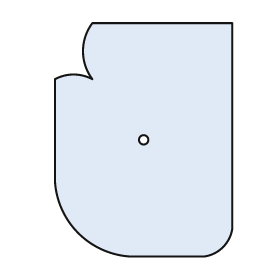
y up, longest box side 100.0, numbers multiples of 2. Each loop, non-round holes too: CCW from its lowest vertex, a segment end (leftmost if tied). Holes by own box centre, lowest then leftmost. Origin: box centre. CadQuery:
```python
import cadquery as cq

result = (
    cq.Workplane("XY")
    .moveTo(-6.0, -50.0)
    .lineTo(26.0, -50.0)
    .threePointArc((34.0, -46.0), (38.0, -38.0))
    .lineTo(38.0, 50.0)
    .lineTo(-22.0, 50.0)
    .threePointArc((-26.0, 38.0), (-22.0, 26.0))
    .threePointArc((-30.0, 28.0), (-38.0, 26.0))
    .lineTo(-38.0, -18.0)
    .threePointArc((-28.0, -40.0), (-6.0, -50.0))
    .close()
    .moveTo(0.0, 0.0)
    .circle(2.0)
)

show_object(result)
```